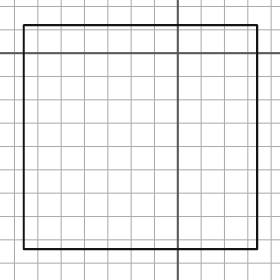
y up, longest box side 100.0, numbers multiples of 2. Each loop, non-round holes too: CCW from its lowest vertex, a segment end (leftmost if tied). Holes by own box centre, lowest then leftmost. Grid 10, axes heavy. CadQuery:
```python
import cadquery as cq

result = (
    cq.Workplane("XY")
    .moveTo(-66.0, -84.0)
    .lineTo(34.0, -84.0)
    .lineTo(34.0, 12.0)
    .lineTo(-66.0, 12.0)
    .close()
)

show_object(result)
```